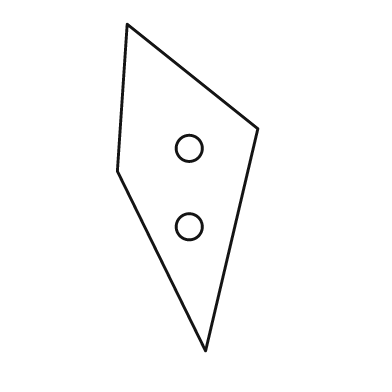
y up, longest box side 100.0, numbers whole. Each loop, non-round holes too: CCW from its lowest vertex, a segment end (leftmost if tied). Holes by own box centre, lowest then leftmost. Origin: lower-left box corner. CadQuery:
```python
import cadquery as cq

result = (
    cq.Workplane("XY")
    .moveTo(27.0, 0.0)
    .lineTo(43.0, 68.0)
    .lineTo(3.0, 100.0)
    .lineTo(0.0, 55.0)
    .close()
    .moveTo(22.0, 38.0)
    .circle(4.0)
    .moveTo(22.0, 62.0)
    .circle(4.0)
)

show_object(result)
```